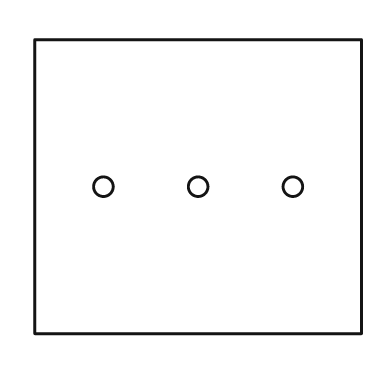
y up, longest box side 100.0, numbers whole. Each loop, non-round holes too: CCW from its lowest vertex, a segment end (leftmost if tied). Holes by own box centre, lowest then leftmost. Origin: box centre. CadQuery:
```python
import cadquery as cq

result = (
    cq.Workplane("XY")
    .moveTo(-50.0, -45.0)
    .lineTo(50.0, -45.0)
    .lineTo(50.0, 45.0)
    .lineTo(-50.0, 45.0)
    .close()
    .moveTo(-29.0, 0.0)
    .circle(3.0)
    .moveTo(0.0, 0.0)
    .circle(3.0)
    .moveTo(29.0, 0.0)
    .circle(3.0)
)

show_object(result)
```